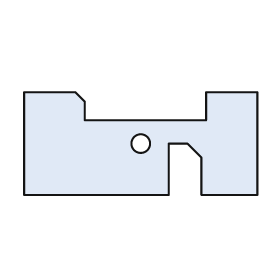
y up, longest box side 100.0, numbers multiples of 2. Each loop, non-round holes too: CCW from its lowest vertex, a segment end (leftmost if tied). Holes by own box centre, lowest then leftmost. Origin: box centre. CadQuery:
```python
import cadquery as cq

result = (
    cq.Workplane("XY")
    .moveTo(-50.0, -22.0)
    .lineTo(12.0, -22.0)
    .lineTo(12.0, 0.0)
    .lineTo(20.0, 0.0)
    .lineTo(26.0, -6.0)
    .lineTo(26.0, -22.0)
    .lineTo(50.0, -22.0)
    .lineTo(50.0, 22.0)
    .lineTo(28.0, 22.0)
    .lineTo(28.0, 10.0)
    .lineTo(-24.0, 10.0)
    .lineTo(-24.0, 18.0)
    .lineTo(-28.0, 22.0)
    .lineTo(-50.0, 22.0)
    .close()
    .moveTo(0.0, 0.0)
    .circle(4.0)
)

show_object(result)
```